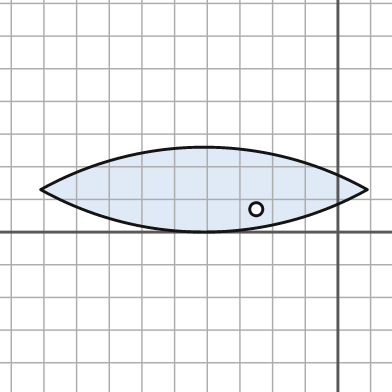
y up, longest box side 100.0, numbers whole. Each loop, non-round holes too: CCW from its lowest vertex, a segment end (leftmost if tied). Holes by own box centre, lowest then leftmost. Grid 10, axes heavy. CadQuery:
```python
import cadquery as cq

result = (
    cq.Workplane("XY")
    .moveTo(-91.0, 13.0)
    .threePointArc((-41.0, 0.0), (9.0, 13.0))
    .threePointArc((-41.0, 26.0), (-91.0, 13.0))
    .close()
    .moveTo(-25.0, 7.0)
    .circle(2.0)
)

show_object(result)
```